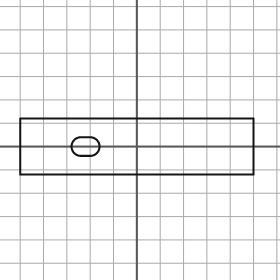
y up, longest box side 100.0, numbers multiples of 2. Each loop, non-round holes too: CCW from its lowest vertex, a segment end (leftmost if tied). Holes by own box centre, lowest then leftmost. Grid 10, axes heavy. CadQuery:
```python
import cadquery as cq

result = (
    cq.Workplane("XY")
    .moveTo(-50.0, -12.0)
    .lineTo(50.0, -12.0)
    .lineTo(50.0, 12.0)
    .lineTo(-50.0, 12.0)
    .close()
    .moveTo(-24.0, -4.0)
    .lineTo(-20.0, -4.0)
    .threePointArc((-16.0, 0.0), (-20.0, 4.0))
    .lineTo(-24.0, 4.0)
    .threePointArc((-28.0, 0.0), (-24.0, -4.0))
    .close()
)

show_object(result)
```